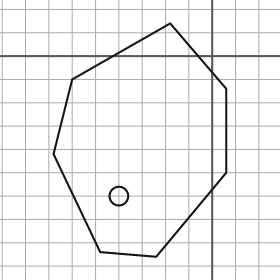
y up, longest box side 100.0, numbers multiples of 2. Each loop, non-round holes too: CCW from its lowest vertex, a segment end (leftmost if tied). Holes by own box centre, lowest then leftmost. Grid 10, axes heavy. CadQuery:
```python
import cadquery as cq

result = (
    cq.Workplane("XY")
    .moveTo(-24.0, -86.0)
    .lineTo(6.0, -50.0)
    .lineTo(6.0, -14.0)
    .lineTo(-18.0, 14.0)
    .lineTo(-60.0, -10.0)
    .lineTo(-68.0, -42.0)
    .lineTo(-48.0, -84.0)
    .close()
    .moveTo(-40.0, -60.0)
    .circle(4.0)
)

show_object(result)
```